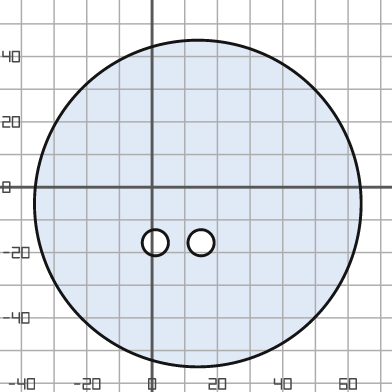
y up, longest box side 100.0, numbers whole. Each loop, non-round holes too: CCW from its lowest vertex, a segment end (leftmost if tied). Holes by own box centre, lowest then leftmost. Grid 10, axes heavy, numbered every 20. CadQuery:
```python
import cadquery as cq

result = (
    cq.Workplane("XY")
    .moveTo(14.0, -5.0)
    .circle(50.0)
    .moveTo(1.0, -17.0)
    .circle(4.0)
    .moveTo(15.0, -17.0)
    .circle(4.0)
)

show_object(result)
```